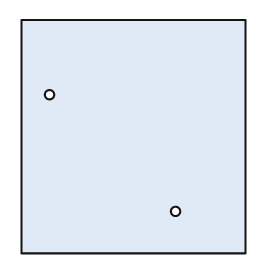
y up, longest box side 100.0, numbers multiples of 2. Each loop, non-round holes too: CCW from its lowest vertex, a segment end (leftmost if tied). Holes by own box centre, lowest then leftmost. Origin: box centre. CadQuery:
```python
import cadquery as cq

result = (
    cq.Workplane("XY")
    .moveTo(-48.0, -50.0)
    .lineTo(48.0, -50.0)
    .lineTo(48.0, 50.0)
    .lineTo(-48.0, 50.0)
    .close()
    .moveTo(18.0, -32.0)
    .circle(2.0)
    .moveTo(-36.0, 18.0)
    .circle(2.0)
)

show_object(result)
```